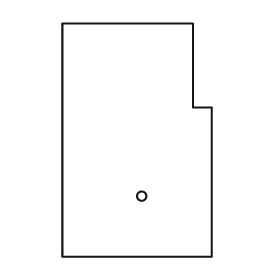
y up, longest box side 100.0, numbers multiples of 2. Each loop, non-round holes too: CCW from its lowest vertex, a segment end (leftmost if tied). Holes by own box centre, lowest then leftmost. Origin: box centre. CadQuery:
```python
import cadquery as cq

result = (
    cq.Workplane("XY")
    .moveTo(-32.0, -50.0)
    .lineTo(32.0, -50.0)
    .lineTo(32.0, 14.0)
    .lineTo(24.0, 14.0)
    .lineTo(24.0, 50.0)
    .lineTo(-32.0, 50.0)
    .close()
    .moveTo(2.0, -24.0)
    .circle(2.0)
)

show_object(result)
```